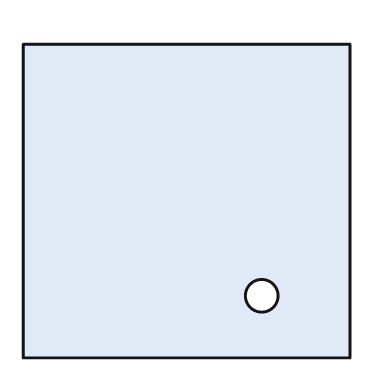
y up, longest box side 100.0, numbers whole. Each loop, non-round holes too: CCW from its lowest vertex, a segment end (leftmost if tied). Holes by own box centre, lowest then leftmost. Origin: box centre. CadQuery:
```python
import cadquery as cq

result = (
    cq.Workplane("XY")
    .moveTo(-50.0, -48.0)
    .lineTo(50.0, -48.0)
    .lineTo(50.0, 48.0)
    .lineTo(-50.0, 48.0)
    .close()
    .moveTo(23.0, -29.0)
    .circle(5.0)
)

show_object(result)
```